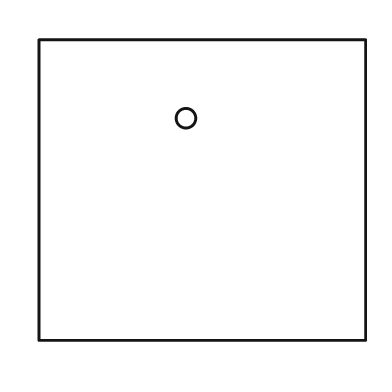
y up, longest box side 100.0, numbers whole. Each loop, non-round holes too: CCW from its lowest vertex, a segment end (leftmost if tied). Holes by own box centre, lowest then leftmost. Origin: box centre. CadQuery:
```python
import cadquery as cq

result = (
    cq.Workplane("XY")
    .moveTo(-50.0, -46.0)
    .lineTo(50.0, -46.0)
    .lineTo(50.0, 46.0)
    .lineTo(-50.0, 46.0)
    .close()
    .moveTo(-5.0, 22.0)
    .circle(3.0)
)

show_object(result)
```